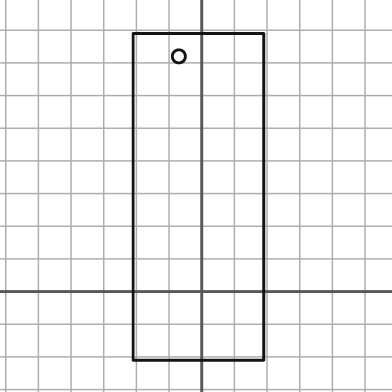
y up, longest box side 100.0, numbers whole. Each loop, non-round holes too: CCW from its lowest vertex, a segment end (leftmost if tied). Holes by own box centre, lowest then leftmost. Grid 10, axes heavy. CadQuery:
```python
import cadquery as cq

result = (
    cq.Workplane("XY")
    .moveTo(-21.0, -21.0)
    .lineTo(19.0, -21.0)
    .lineTo(19.0, 79.0)
    .lineTo(-21.0, 79.0)
    .close()
    .moveTo(-7.0, 72.0)
    .circle(2.0)
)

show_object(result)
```